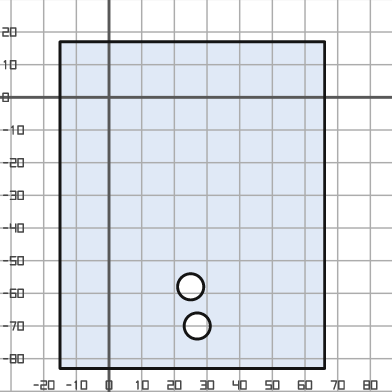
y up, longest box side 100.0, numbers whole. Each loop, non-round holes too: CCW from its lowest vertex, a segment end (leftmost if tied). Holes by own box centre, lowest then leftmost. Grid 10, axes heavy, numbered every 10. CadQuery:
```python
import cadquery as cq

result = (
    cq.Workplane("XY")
    .moveTo(-15.0, -83.0)
    .lineTo(66.0, -83.0)
    .lineTo(66.0, 17.0)
    .lineTo(-15.0, 17.0)
    .close()
    .moveTo(27.0, -70.0)
    .circle(4.0)
    .moveTo(25.0, -58.0)
    .circle(4.0)
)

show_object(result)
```